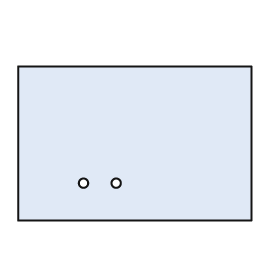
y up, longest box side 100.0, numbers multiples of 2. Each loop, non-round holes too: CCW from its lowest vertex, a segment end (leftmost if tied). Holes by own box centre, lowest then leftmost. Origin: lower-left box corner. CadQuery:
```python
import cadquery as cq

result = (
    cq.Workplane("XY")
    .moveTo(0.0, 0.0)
    .lineTo(100.0, 0.0)
    .lineTo(100.0, 66.0)
    .lineTo(0.0, 66.0)
    .close()
    .moveTo(28.0, 16.0)
    .circle(2.0)
    .moveTo(42.0, 16.0)
    .circle(2.0)
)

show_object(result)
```